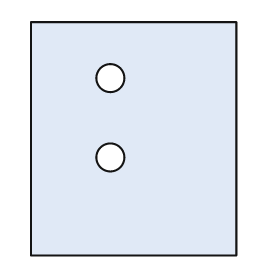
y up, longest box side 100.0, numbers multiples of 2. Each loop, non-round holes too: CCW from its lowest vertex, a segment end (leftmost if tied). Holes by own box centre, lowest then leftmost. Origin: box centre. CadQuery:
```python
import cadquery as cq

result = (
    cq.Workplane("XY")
    .moveTo(-44.0, -50.0)
    .lineTo(44.0, -50.0)
    .lineTo(44.0, 50.0)
    .lineTo(-44.0, 50.0)
    .close()
    .moveTo(-10.0, -8.0)
    .circle(6.0)
    .moveTo(-10.0, 26.0)
    .circle(6.0)
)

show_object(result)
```